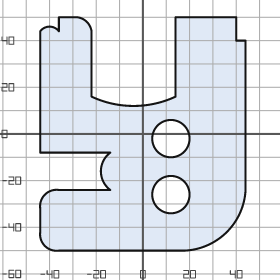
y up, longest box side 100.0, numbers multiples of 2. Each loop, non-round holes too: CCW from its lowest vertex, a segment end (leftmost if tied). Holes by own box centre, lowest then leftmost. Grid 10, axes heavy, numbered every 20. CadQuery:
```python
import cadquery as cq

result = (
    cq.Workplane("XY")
    .moveTo(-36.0, -50.0)
    .lineTo(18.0, -50.0)
    .threePointArc((36.0, -42.0), (44.0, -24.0))
    .lineTo(44.0, 40.0)
    .lineTo(40.0, 40.0)
    .lineTo(40.0, 50.0)
    .lineTo(14.0, 50.0)
    .lineTo(14.0, 16.0)
    .threePointArc((-4.0, 12.0), (-22.0, 16.0))
    .lineTo(-22.0, 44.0)
    .threePointArc((-24.0, 48.0), (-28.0, 50.0))
    .lineTo(-36.0, 50.0)
    .lineTo(-36.0, 44.0)
    .threePointArc((-40.0, 46.0), (-44.0, 44.0))
    .lineTo(-44.0, -8.0)
    .lineTo(-14.0, -8.0)
    .threePointArc((-18.0, -16.0), (-14.0, -24.0))
    .lineTo(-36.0, -24.0)
    .threePointArc((-42.0, -26.0), (-44.0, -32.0))
    .lineTo(-44.0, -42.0)
    .threePointArc((-42.0, -48.0), (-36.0, -50.0))
    .close()
    .moveTo(12.0, -26.0)
    .circle(8.0)
    .moveTo(12.0, -2.0)
    .circle(8.0)
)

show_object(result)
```